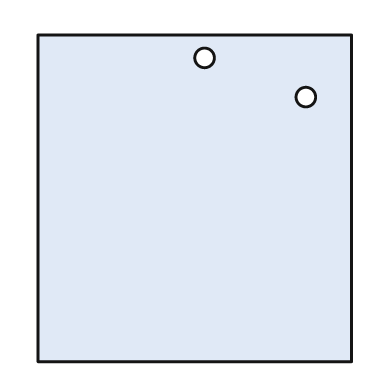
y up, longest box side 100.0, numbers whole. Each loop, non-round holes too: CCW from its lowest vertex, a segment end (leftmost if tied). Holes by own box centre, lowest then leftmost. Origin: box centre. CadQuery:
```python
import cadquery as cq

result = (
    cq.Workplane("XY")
    .moveTo(-48.0, -50.0)
    .lineTo(48.0, -50.0)
    .lineTo(48.0, 50.0)
    .lineTo(-48.0, 50.0)
    .close()
    .moveTo(34.0, 31.0)
    .circle(3.0)
    .moveTo(3.0, 43.0)
    .circle(3.0)
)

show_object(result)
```